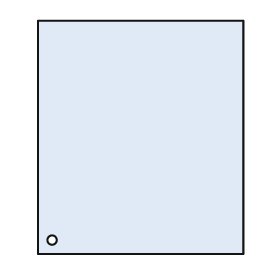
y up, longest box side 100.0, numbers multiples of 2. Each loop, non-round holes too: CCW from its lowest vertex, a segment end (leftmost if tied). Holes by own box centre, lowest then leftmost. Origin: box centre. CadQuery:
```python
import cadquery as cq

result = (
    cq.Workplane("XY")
    .moveTo(-44.0, -50.0)
    .lineTo(44.0, -50.0)
    .lineTo(44.0, 50.0)
    .lineTo(-44.0, 50.0)
    .close()
    .moveTo(-38.0, -44.0)
    .circle(2.0)
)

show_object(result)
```